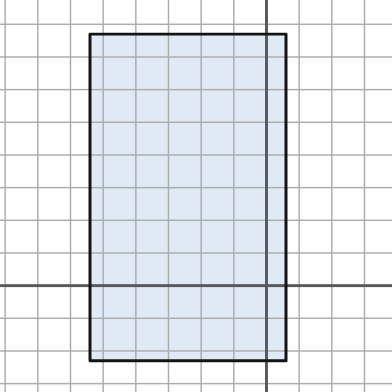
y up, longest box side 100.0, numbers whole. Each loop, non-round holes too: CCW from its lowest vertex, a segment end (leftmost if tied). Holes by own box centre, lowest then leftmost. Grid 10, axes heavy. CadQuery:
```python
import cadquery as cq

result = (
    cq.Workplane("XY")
    .moveTo(-54.0, -23.0)
    .lineTo(6.0, -23.0)
    .lineTo(6.0, 77.0)
    .lineTo(-54.0, 77.0)
    .close()
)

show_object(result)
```